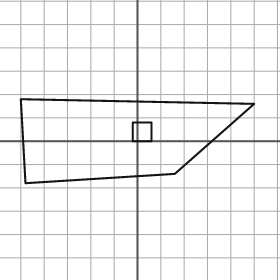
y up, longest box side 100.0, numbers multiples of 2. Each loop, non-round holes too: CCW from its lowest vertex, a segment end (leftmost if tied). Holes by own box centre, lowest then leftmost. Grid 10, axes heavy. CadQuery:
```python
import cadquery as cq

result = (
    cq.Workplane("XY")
    .moveTo(-48.0, -18.0)
    .lineTo(16.0, -14.0)
    .lineTo(50.0, 16.0)
    .lineTo(-50.0, 18.0)
    .close()
    .moveTo(-2.0, 0.0)
    .lineTo(6.0, 0.0)
    .lineTo(6.0, 8.0)
    .lineTo(-2.0, 8.0)
    .close()
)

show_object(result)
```